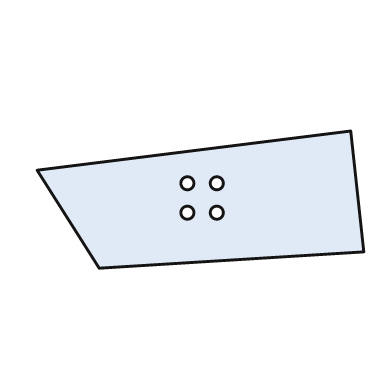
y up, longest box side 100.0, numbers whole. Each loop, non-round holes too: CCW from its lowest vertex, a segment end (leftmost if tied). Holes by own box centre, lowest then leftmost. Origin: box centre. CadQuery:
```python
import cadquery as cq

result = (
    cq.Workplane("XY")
    .moveTo(-31.0, -21.0)
    .lineTo(50.0, -16.0)
    .lineTo(46.0, 21.0)
    .lineTo(-50.0, 9.0)
    .close()
    .moveTo(-4.0, -4.0)
    .circle(2.0)
    .moveTo(5.0, -4.0)
    .circle(2.0)
    .moveTo(-4.0, 5.0)
    .circle(2.0)
    .moveTo(5.0, 5.0)
    .circle(2.0)
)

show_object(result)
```